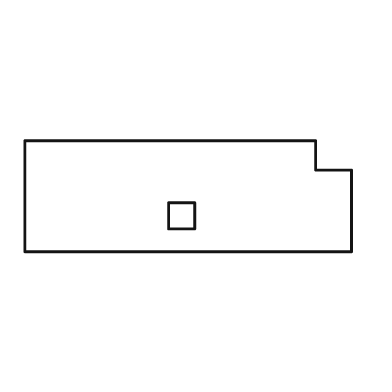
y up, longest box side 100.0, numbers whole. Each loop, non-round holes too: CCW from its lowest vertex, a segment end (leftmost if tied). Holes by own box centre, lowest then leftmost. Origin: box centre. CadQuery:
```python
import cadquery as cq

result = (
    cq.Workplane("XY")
    .moveTo(-50.0, -17.0)
    .lineTo(50.0, -17.0)
    .lineTo(50.0, 8.0)
    .lineTo(39.0, 8.0)
    .lineTo(39.0, 17.0)
    .lineTo(-50.0, 17.0)
    .close()
    .moveTo(-6.0, -10.0)
    .lineTo(2.0, -10.0)
    .lineTo(2.0, -2.0)
    .lineTo(-6.0, -2.0)
    .close()
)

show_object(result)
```